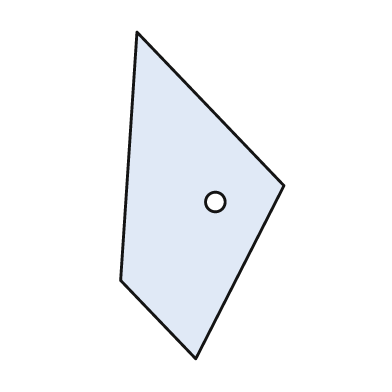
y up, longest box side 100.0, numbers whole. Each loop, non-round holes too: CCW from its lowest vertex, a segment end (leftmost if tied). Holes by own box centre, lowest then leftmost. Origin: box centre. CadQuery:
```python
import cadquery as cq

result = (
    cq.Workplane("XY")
    .moveTo(-2.0, -50.0)
    .lineTo(25.0, 3.0)
    .lineTo(-20.0, 50.0)
    .lineTo(-25.0, -26.0)
    .close()
    .moveTo(4.0, -2.0)
    .circle(3.0)
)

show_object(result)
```